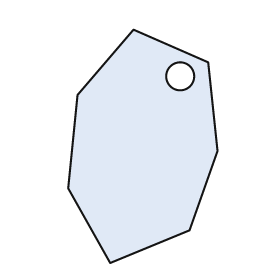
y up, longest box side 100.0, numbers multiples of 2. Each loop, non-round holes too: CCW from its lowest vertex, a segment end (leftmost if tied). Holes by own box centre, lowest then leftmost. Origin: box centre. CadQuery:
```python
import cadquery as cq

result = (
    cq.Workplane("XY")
    .moveTo(-14.0, -50.0)
    .lineTo(20.0, -36.0)
    .lineTo(32.0, -2.0)
    .lineTo(28.0, 36.0)
    .lineTo(-4.0, 50.0)
    .lineTo(-28.0, 22.0)
    .lineTo(-32.0, -18.0)
    .close()
    .moveTo(16.0, 30.0)
    .circle(6.0)
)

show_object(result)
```